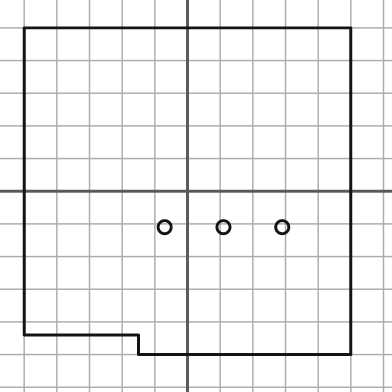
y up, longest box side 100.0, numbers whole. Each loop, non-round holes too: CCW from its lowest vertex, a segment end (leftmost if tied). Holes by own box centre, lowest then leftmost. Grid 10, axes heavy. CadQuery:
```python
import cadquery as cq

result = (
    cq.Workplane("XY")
    .moveTo(-15.0, -50.0)
    .lineTo(50.0, -50.0)
    .lineTo(50.0, 50.0)
    .lineTo(-50.0, 50.0)
    .lineTo(-50.0, -44.0)
    .lineTo(-15.0, -44.0)
    .close()
    .moveTo(-7.0, -11.0)
    .circle(2.0)
    .moveTo(11.0, -11.0)
    .circle(2.0)
    .moveTo(29.0, -11.0)
    .circle(2.0)
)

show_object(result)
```